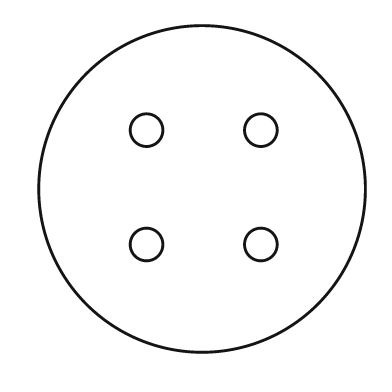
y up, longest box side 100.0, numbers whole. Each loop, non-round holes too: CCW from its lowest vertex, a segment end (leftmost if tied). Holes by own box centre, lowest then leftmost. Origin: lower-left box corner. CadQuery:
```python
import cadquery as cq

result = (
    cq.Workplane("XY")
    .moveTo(50.0, 50.0)
    .circle(50.0)
    .moveTo(33.0, 33.0)
    .circle(5.0)
    .moveTo(68.0, 33.0)
    .circle(5.0)
    .moveTo(33.0, 68.0)
    .circle(5.0)
    .moveTo(68.0, 68.0)
    .circle(5.0)
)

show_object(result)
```